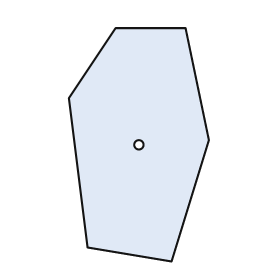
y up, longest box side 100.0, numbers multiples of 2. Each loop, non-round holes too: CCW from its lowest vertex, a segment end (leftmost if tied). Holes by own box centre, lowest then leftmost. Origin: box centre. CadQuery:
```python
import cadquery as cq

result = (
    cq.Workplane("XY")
    .moveTo(14.0, -50.0)
    .lineTo(30.0, 2.0)
    .lineTo(20.0, 50.0)
    .lineTo(-10.0, 50.0)
    .lineTo(-30.0, 20.0)
    .lineTo(-22.0, -44.0)
    .close()
    .moveTo(0.0, 0.0)
    .circle(2.0)
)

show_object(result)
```